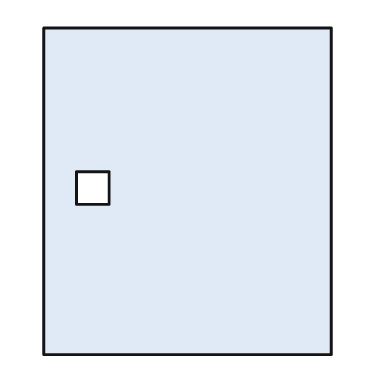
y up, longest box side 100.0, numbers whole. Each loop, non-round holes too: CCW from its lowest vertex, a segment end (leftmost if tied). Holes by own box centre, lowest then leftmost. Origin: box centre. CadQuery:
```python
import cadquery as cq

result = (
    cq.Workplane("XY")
    .moveTo(-44.0, -50.0)
    .lineTo(44.0, -50.0)
    .lineTo(44.0, 50.0)
    .lineTo(-44.0, 50.0)
    .close()
    .moveTo(-34.0, -4.0)
    .lineTo(-24.0, -4.0)
    .lineTo(-24.0, 6.0)
    .lineTo(-34.0, 6.0)
    .close()
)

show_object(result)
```